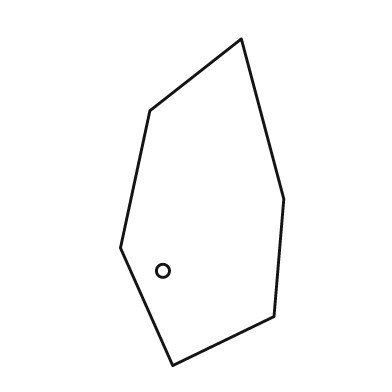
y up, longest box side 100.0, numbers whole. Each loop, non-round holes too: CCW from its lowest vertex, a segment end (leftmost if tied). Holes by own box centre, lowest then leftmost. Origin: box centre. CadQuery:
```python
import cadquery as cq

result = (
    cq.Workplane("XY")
    .moveTo(-9.0, -50.0)
    .lineTo(22.0, -35.0)
    .lineTo(25.0, 1.0)
    .lineTo(12.0, 50.0)
    .lineTo(-16.0, 28.0)
    .lineTo(-25.0, -14.0)
    .close()
    .moveTo(-12.0, -21.0)
    .circle(2.0)
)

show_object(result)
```